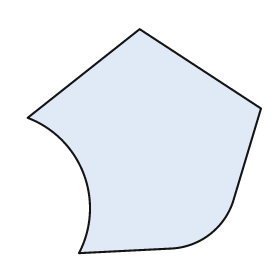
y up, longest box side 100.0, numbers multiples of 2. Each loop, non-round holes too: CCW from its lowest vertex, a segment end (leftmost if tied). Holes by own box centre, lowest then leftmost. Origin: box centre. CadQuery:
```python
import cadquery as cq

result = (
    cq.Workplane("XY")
    .moveTo(-28.0, -48.0)
    .lineTo(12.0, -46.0)
    .threePointArc((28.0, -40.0), (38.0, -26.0))
    .lineTo(50.0, 14.0)
    .lineTo(-2.0, 48.0)
    .lineTo(-50.0, 10.0)
    .threePointArc((-26.0, -14.0), (-28.0, -48.0))
    .close()
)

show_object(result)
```